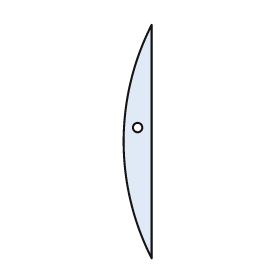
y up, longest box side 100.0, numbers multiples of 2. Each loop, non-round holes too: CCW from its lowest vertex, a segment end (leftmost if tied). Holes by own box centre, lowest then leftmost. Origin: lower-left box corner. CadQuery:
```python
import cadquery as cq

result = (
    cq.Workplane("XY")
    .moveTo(12.0, 0.0)
    .lineTo(12.0, 100.0)
    .threePointArc((0.0, 50.0), (12.0, 0.0))
    .close()
    .moveTo(6.0, 56.0)
    .circle(2.0)
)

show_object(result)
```